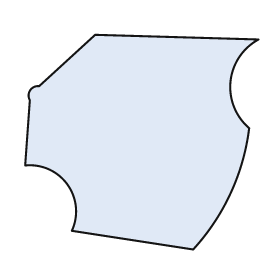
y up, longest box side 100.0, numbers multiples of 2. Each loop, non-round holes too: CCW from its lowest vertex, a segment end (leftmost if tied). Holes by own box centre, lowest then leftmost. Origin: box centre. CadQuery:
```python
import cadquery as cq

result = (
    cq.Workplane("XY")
    .moveTo(22.0, -46.0)
    .threePointArc((38.0, -22.0), (46.0, 6.0))
    .threePointArc((38.0, 26.0), (50.0, 44.0))
    .lineTo(-20.0, 46.0)
    .lineTo(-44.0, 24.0)
    .threePointArc((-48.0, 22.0), (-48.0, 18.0))
    .lineTo(-50.0, -10.0)
    .threePointArc((-32.0, -18.0), (-30.0, -38.0))
    .close()
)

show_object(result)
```